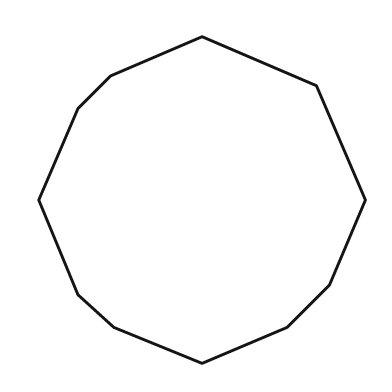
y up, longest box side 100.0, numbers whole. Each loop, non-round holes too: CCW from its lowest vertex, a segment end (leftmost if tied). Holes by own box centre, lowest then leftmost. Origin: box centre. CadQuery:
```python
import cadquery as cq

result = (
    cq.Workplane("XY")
    .moveTo(0.0, -50.0)
    .lineTo(26.0, -39.0)
    .lineTo(39.0, -26.0)
    .lineTo(50.0, 0.0)
    .lineTo(35.0, 35.0)
    .lineTo(0.0, 50.0)
    .lineTo(-28.0, 38.0)
    .lineTo(-38.0, 28.0)
    .lineTo(-50.0, 0.0)
    .lineTo(-38.0, -29.0)
    .lineTo(-27.0, -39.0)
    .close()
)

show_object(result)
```